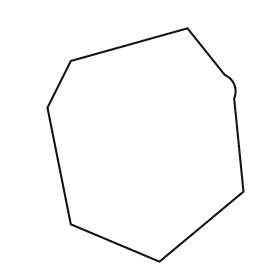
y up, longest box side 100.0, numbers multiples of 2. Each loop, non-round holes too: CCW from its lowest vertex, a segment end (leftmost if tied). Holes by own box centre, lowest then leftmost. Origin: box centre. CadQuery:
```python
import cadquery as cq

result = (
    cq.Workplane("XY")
    .moveTo(6.0, -50.0)
    .lineTo(42.0, -20.0)
    .lineTo(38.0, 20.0)
    .threePointArc((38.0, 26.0), (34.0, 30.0))
    .lineTo(18.0, 50.0)
    .lineTo(-32.0, 36.0)
    .lineTo(-42.0, 16.0)
    .lineTo(-32.0, -34.0)
    .close()
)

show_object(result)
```